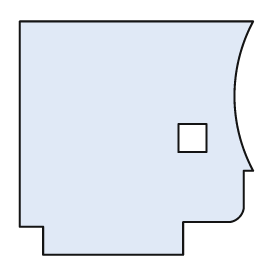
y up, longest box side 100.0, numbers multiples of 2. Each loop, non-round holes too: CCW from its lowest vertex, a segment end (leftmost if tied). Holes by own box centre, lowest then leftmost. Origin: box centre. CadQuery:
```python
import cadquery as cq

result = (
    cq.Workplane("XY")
    .moveTo(-40.0, -50.0)
    .lineTo(20.0, -50.0)
    .lineTo(20.0, -36.0)
    .lineTo(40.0, -36.0)
    .threePointArc((44.0, -34.0), (46.0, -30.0))
    .lineTo(46.0, -14.0)
    .lineTo(50.0, -14.0)
    .threePointArc((42.0, 18.0), (50.0, 50.0))
    .lineTo(-50.0, 50.0)
    .lineTo(-50.0, -38.0)
    .lineTo(-40.0, -38.0)
    .close()
    .moveTo(18.0, -6.0)
    .lineTo(30.0, -6.0)
    .lineTo(30.0, 6.0)
    .lineTo(18.0, 6.0)
    .close()
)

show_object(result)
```